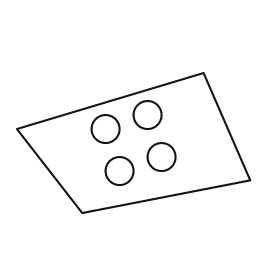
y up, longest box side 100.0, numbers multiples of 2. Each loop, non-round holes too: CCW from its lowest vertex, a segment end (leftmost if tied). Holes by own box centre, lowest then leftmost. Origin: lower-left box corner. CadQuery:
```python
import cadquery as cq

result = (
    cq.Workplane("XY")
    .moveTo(28.0, 0.0)
    .lineTo(100.0, 14.0)
    .lineTo(80.0, 60.0)
    .lineTo(0.0, 36.0)
    .close()
    .moveTo(44.0, 18.0)
    .circle(6.0)
    .moveTo(62.0, 24.0)
    .circle(6.0)
    .moveTo(38.0, 36.0)
    .circle(6.0)
    .moveTo(56.0, 42.0)
    .circle(6.0)
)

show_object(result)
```